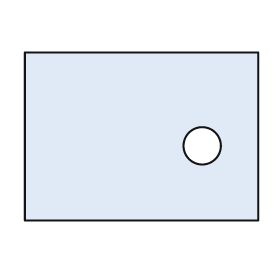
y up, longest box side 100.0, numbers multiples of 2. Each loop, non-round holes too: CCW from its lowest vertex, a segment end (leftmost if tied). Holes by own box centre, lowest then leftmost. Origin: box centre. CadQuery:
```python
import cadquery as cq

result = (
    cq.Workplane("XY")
    .moveTo(-50.0, -36.0)
    .lineTo(50.0, -36.0)
    .lineTo(50.0, 36.0)
    .lineTo(-50.0, 36.0)
    .close()
    .moveTo(26.0, -4.0)
    .circle(8.0)
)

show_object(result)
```